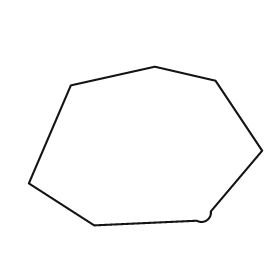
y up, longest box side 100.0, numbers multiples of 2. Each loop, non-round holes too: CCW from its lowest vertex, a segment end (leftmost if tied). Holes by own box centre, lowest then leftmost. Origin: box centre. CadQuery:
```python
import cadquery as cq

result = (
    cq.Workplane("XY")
    .moveTo(-22.0, -34.0)
    .lineTo(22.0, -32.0)
    .threePointArc((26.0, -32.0), (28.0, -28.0))
    .lineTo(50.0, -2.0)
    .lineTo(30.0, 28.0)
    .lineTo(4.0, 34.0)
    .lineTo(-32.0, 26.0)
    .lineTo(-50.0, -16.0)
    .close()
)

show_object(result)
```